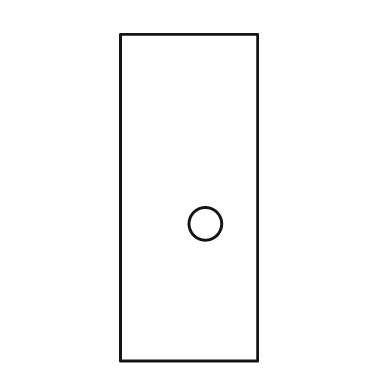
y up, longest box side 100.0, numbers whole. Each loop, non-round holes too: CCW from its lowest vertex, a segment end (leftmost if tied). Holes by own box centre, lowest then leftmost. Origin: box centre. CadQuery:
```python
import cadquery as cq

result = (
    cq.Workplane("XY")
    .moveTo(-21.0, -50.0)
    .lineTo(21.0, -50.0)
    .lineTo(21.0, 50.0)
    .lineTo(-21.0, 50.0)
    .close()
    .moveTo(5.0, -8.0)
    .circle(5.0)
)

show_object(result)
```